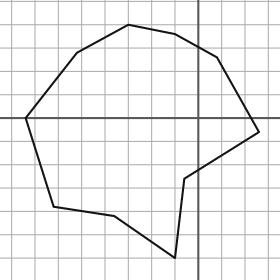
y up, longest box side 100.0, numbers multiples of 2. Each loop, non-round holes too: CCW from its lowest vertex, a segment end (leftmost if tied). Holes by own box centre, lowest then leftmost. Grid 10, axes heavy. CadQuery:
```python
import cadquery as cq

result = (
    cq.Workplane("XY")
    .moveTo(-10.0, -60.0)
    .lineTo(-6.0, -26.0)
    .lineTo(26.0, -6.0)
    .lineTo(8.0, 26.0)
    .lineTo(-10.0, 36.0)
    .lineTo(-30.0, 40.0)
    .lineTo(-52.0, 28.0)
    .lineTo(-74.0, 0.0)
    .lineTo(-62.0, -38.0)
    .lineTo(-36.0, -42.0)
    .close()
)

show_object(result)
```